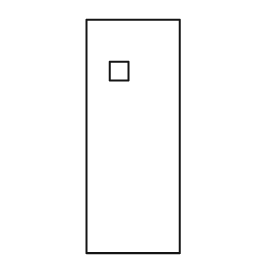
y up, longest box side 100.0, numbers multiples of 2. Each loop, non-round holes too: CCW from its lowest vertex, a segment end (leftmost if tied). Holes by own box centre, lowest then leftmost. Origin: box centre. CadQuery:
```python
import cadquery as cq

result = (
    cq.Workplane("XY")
    .moveTo(-20.0, -50.0)
    .lineTo(20.0, -50.0)
    .lineTo(20.0, 50.0)
    .lineTo(-20.0, 50.0)
    .close()
    .moveTo(-10.0, 24.0)
    .lineTo(-2.0, 24.0)
    .lineTo(-2.0, 32.0)
    .lineTo(-10.0, 32.0)
    .close()
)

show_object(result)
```